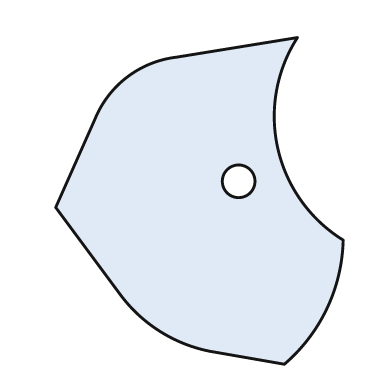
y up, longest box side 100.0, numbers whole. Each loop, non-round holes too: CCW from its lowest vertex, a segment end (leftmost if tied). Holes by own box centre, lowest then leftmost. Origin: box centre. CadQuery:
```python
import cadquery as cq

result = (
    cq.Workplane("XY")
    .moveTo(26.0, -50.0)
    .threePointArc((39.0, -33.0), (44.0, -12.0))
    .threePointArc((24.0, 16.0), (30.0, 50.0))
    .lineTo(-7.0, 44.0)
    .threePointArc((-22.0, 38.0), (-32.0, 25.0))
    .lineTo(-44.0, -2.0)
    .lineTo(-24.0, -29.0)
    .threePointArc((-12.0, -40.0), (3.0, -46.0))
    .close()
    .moveTo(12.0, 6.0)
    .circle(5.0)
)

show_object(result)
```